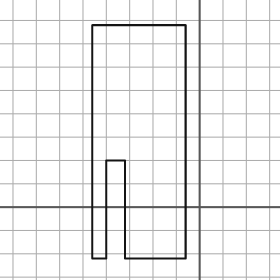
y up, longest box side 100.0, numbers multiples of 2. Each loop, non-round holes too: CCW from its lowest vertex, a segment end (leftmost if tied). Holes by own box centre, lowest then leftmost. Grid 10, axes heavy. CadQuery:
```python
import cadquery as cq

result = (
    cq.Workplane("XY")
    .moveTo(-46.0, -22.0)
    .lineTo(-40.0, -22.0)
    .lineTo(-40.0, 20.0)
    .lineTo(-32.0, 20.0)
    .lineTo(-32.0, -22.0)
    .lineTo(-6.0, -22.0)
    .lineTo(-6.0, 78.0)
    .lineTo(-46.0, 78.0)
    .close()
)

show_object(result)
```